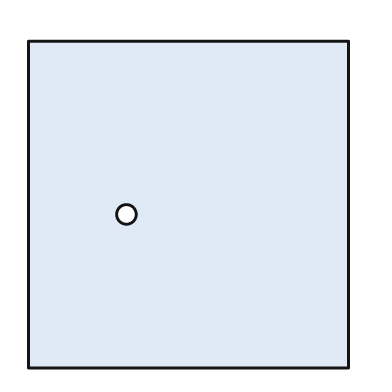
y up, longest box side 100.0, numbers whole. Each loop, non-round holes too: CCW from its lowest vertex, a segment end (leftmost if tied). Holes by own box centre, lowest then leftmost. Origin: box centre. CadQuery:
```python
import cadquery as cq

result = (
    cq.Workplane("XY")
    .moveTo(-49.0, -50.0)
    .lineTo(49.0, -50.0)
    .lineTo(49.0, 50.0)
    .lineTo(-49.0, 50.0)
    .close()
    .moveTo(-19.0, -3.0)
    .circle(3.0)
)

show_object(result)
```